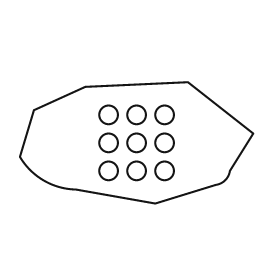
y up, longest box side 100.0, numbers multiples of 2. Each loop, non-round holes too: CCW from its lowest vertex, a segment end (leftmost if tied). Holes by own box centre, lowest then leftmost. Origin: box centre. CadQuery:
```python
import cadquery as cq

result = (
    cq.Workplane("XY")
    .moveTo(8.0, -26.0)
    .lineTo(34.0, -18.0)
    .threePointArc((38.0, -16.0), (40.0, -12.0))
    .lineTo(50.0, 4.0)
    .lineTo(22.0, 26.0)
    .lineTo(-22.0, 24.0)
    .lineTo(-44.0, 14.0)
    .lineTo(-50.0, -6.0)
    .threePointArc((-40.0, -16.0), (-26.0, -20.0))
    .close()
    .moveTo(-12.0, -12.0)
    .circle(4.0)
    .moveTo(0.0, -12.0)
    .circle(4.0)
    .moveTo(12.0, -12.0)
    .circle(4.0)
    .moveTo(-12.0, 0.0)
    .circle(4.0)
    .moveTo(0.0, 0.0)
    .circle(4.0)
    .moveTo(12.0, 0.0)
    .circle(4.0)
    .moveTo(-12.0, 12.0)
    .circle(4.0)
    .moveTo(0.0, 12.0)
    .circle(4.0)
    .moveTo(12.0, 12.0)
    .circle(4.0)
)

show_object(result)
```